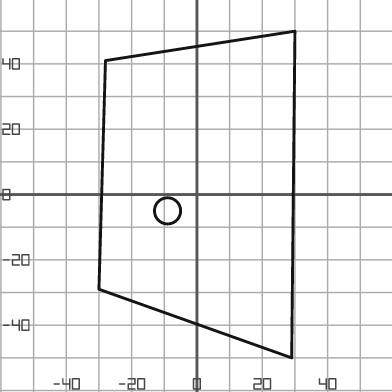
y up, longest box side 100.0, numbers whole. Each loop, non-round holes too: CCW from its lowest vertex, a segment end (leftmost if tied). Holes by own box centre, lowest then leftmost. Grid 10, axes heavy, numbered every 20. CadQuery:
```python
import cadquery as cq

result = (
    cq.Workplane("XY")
    .moveTo(29.0, -50.0)
    .lineTo(30.0, 50.0)
    .lineTo(-28.0, 41.0)
    .lineTo(-30.0, -29.0)
    .close()
    .moveTo(-9.0, -5.0)
    .circle(4.0)
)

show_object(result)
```